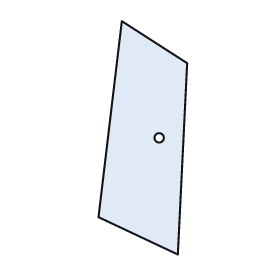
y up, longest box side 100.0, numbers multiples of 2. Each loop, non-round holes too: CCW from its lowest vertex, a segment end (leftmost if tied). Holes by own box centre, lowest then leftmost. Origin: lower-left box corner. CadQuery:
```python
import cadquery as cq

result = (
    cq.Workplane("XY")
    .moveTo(34.0, 0.0)
    .lineTo(38.0, 82.0)
    .lineTo(10.0, 100.0)
    .lineTo(0.0, 16.0)
    .close()
    .moveTo(26.0, 50.0)
    .circle(2.0)
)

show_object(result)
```